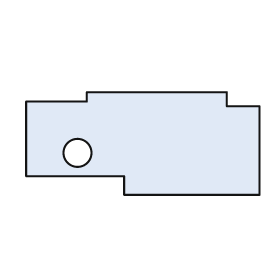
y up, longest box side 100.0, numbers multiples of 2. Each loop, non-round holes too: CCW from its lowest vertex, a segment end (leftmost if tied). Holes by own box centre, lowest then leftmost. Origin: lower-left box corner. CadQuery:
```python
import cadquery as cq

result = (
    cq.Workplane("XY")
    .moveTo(42.0, 0.0)
    .lineTo(100.0, 0.0)
    .lineTo(100.0, 38.0)
    .lineTo(86.0, 38.0)
    .lineTo(86.0, 44.0)
    .lineTo(26.0, 44.0)
    .lineTo(26.0, 40.0)
    .lineTo(0.0, 40.0)
    .lineTo(0.0, 8.0)
    .lineTo(42.0, 8.0)
    .close()
    .moveTo(22.0, 18.0)
    .circle(6.0)
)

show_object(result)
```